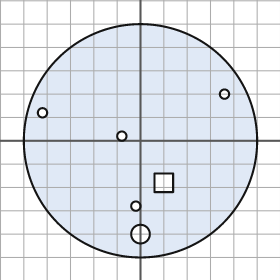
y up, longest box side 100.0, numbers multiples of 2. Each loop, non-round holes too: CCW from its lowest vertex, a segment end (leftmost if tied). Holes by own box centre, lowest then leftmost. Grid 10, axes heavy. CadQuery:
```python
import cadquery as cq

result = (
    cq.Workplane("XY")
    .moveTo(0.0, 0.0)
    .circle(50.0)
    .moveTo(0.0, -40.0)
    .circle(4.0)
    .moveTo(-2.0, -28.0)
    .circle(2.0)
    .moveTo(6.0, -22.0)
    .lineTo(14.0, -22.0)
    .lineTo(14.0, -14.0)
    .lineTo(6.0, -14.0)
    .close()
    .moveTo(-8.0, 2.0)
    .circle(2.0)
    .moveTo(-42.0, 12.0)
    .circle(2.0)
    .moveTo(36.0, 20.0)
    .circle(2.0)
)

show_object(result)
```